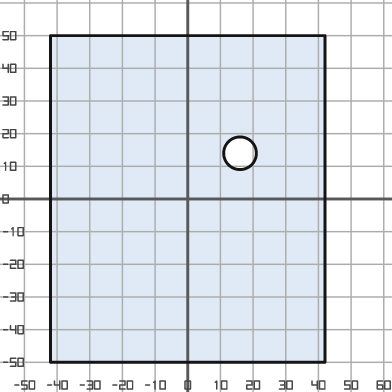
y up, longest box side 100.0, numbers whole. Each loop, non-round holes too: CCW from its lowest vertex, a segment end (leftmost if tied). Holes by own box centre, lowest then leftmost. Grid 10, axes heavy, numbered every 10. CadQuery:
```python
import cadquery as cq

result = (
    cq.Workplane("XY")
    .moveTo(-42.0, -50.0)
    .lineTo(42.0, -50.0)
    .lineTo(42.0, 50.0)
    .lineTo(-42.0, 50.0)
    .close()
    .moveTo(16.0, 14.0)
    .circle(5.0)
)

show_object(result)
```